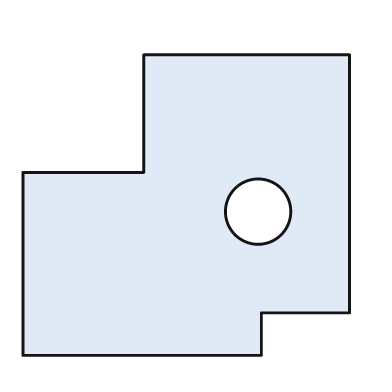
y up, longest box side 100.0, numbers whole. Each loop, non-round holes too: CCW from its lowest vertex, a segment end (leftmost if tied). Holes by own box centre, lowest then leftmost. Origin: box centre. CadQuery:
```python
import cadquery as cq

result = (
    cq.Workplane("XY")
    .moveTo(-50.0, -46.0)
    .lineTo(23.0, -46.0)
    .lineTo(23.0, -33.0)
    .lineTo(50.0, -33.0)
    .lineTo(50.0, 46.0)
    .lineTo(-13.0, 46.0)
    .lineTo(-13.0, 10.0)
    .lineTo(-50.0, 10.0)
    .close()
    .moveTo(22.0, -2.0)
    .circle(10.0)
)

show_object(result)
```